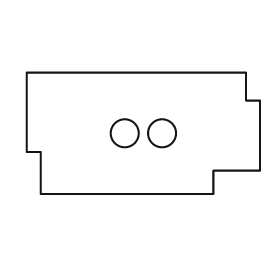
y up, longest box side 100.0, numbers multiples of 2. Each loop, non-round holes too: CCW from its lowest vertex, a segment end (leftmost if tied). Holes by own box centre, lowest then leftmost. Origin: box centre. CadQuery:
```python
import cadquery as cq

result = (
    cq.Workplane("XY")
    .moveTo(-44.0, -26.0)
    .lineTo(30.0, -26.0)
    .lineTo(30.0, -16.0)
    .lineTo(50.0, -16.0)
    .lineTo(50.0, 14.0)
    .lineTo(44.0, 14.0)
    .lineTo(44.0, 26.0)
    .lineTo(-50.0, 26.0)
    .lineTo(-50.0, -8.0)
    .lineTo(-44.0, -8.0)
    .close()
    .moveTo(-8.0, 0.0)
    .circle(6.0)
    .moveTo(8.0, 0.0)
    .circle(6.0)
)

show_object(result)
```